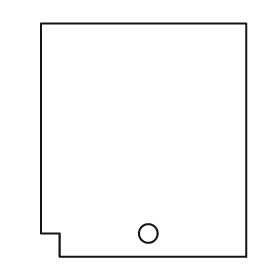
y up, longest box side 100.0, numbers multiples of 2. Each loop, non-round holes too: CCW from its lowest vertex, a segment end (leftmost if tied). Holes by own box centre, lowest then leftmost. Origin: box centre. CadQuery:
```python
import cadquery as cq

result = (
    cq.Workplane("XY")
    .moveTo(-36.0, -50.0)
    .lineTo(44.0, -50.0)
    .lineTo(44.0, 50.0)
    .lineTo(-44.0, 50.0)
    .lineTo(-44.0, -40.0)
    .lineTo(-36.0, -40.0)
    .close()
    .moveTo(2.0, -40.0)
    .circle(4.0)
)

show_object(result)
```